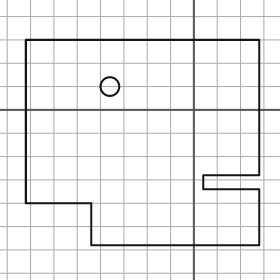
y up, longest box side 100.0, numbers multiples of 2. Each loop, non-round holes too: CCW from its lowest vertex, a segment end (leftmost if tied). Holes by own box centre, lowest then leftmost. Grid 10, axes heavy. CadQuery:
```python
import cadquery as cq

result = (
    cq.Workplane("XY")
    .moveTo(-44.0, -58.0)
    .lineTo(28.0, -58.0)
    .lineTo(28.0, -34.0)
    .lineTo(4.0, -34.0)
    .lineTo(4.0, -28.0)
    .lineTo(28.0, -28.0)
    .lineTo(28.0, 30.0)
    .lineTo(-72.0, 30.0)
    .lineTo(-72.0, -40.0)
    .lineTo(-44.0, -40.0)
    .close()
    .moveTo(-36.0, 10.0)
    .circle(4.0)
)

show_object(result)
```